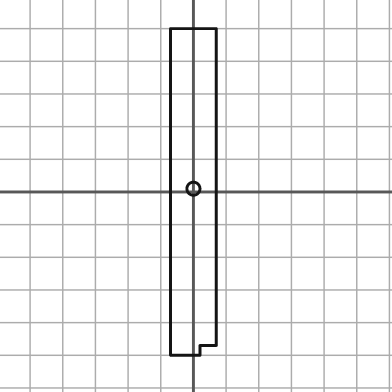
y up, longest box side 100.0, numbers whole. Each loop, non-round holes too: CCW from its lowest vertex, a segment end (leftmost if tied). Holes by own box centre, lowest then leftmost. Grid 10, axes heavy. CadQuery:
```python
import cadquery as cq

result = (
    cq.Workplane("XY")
    .moveTo(-7.0, -50.0)
    .lineTo(2.0, -50.0)
    .lineTo(2.0, -47.0)
    .lineTo(7.0, -47.0)
    .lineTo(7.0, 50.0)
    .lineTo(-7.0, 50.0)
    .close()
    .moveTo(0.0, 1.0)
    .circle(2.0)
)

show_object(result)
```